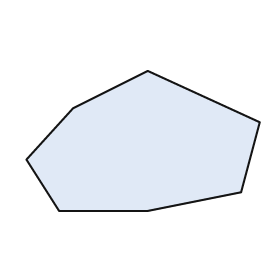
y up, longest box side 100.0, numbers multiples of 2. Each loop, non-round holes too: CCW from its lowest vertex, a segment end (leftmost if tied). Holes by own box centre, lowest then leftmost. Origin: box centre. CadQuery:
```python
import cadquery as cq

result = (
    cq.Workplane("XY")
    .moveTo(-36.0, -30.0)
    .lineTo(2.0, -30.0)
    .lineTo(42.0, -22.0)
    .lineTo(50.0, 8.0)
    .lineTo(2.0, 30.0)
    .lineTo(-30.0, 14.0)
    .lineTo(-50.0, -8.0)
    .close()
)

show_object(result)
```